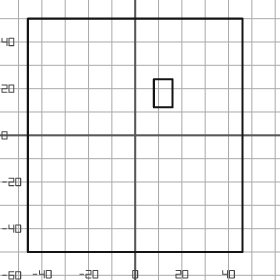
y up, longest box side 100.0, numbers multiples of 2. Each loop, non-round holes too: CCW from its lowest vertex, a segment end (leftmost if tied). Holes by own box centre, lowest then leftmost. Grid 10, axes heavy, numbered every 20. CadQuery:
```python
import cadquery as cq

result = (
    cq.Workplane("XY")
    .moveTo(-46.0, -50.0)
    .lineTo(46.0, -50.0)
    .lineTo(46.0, 50.0)
    .lineTo(-46.0, 50.0)
    .close()
    .moveTo(8.0, 12.0)
    .lineTo(16.0, 12.0)
    .lineTo(16.0, 24.0)
    .lineTo(8.0, 24.0)
    .close()
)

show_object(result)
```